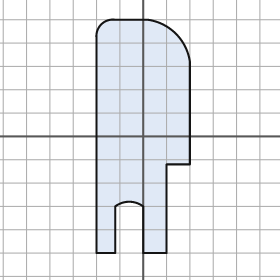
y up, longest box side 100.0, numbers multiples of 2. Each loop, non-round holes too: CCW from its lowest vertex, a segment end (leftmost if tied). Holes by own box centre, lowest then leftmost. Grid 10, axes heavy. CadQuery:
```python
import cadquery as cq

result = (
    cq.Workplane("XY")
    .moveTo(-20.0, -50.0)
    .lineTo(-12.0, -50.0)
    .lineTo(-12.0, -30.0)
    .threePointArc((-6.0, -28.0), (0.0, -30.0))
    .lineTo(0.0, -50.0)
    .lineTo(10.0, -50.0)
    .lineTo(10.0, -12.0)
    .lineTo(20.0, -12.0)
    .lineTo(20.0, 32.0)
    .threePointArc((14.0, 44.0), (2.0, 50.0))
    .lineTo(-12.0, 50.0)
    .threePointArc((-18.0, 48.0), (-20.0, 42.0))
    .close()
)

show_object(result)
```